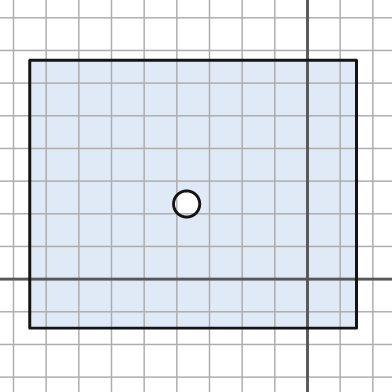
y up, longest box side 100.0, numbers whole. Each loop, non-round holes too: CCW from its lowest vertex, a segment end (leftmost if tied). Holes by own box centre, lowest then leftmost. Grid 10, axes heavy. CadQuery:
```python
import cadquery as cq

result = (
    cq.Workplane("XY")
    .moveTo(-85.0, -15.0)
    .lineTo(15.0, -15.0)
    .lineTo(15.0, 67.0)
    .lineTo(-85.0, 67.0)
    .close()
    .moveTo(-37.0, 23.0)
    .circle(4.0)
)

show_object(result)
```